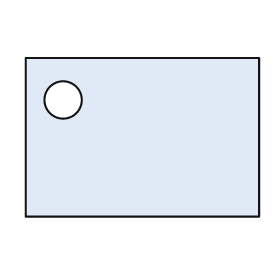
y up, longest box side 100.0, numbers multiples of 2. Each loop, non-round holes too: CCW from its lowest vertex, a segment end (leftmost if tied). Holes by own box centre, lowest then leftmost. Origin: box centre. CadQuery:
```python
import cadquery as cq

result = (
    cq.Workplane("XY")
    .moveTo(-50.0, -34.0)
    .lineTo(50.0, -34.0)
    .lineTo(50.0, 34.0)
    .lineTo(-50.0, 34.0)
    .close()
    .moveTo(-34.0, 16.0)
    .circle(8.0)
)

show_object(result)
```